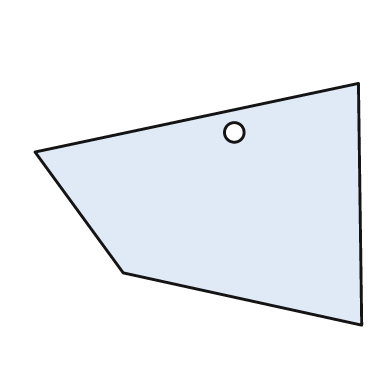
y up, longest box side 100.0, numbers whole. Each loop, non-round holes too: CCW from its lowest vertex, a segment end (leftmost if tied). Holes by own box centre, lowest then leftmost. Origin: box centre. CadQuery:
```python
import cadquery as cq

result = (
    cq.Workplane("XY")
    .moveTo(50.0, -37.0)
    .lineTo(49.0, 37.0)
    .lineTo(-50.0, 16.0)
    .lineTo(-23.0, -21.0)
    .close()
    .moveTo(11.0, 22.0)
    .circle(3.0)
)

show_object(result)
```